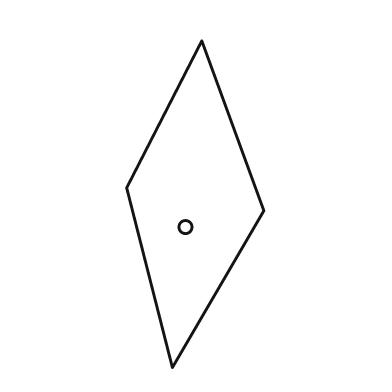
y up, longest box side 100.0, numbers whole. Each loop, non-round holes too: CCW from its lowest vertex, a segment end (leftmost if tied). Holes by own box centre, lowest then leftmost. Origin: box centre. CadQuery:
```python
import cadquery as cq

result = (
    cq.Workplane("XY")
    .moveTo(-7.0, -50.0)
    .lineTo(21.0, -2.0)
    .lineTo(2.0, 50.0)
    .lineTo(-21.0, 5.0)
    .close()
    .moveTo(-3.0, -7.0)
    .circle(2.0)
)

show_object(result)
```